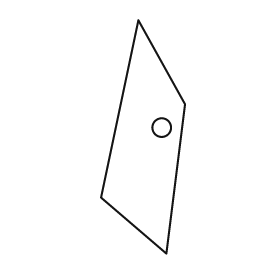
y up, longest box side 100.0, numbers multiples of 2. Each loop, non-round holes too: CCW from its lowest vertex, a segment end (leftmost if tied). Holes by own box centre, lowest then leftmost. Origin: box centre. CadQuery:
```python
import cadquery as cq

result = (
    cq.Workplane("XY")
    .moveTo(10.0, -50.0)
    .lineTo(18.0, 14.0)
    .lineTo(-2.0, 50.0)
    .lineTo(-18.0, -26.0)
    .close()
    .moveTo(8.0, 4.0)
    .circle(4.0)
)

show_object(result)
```